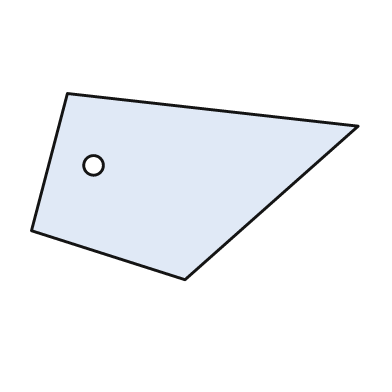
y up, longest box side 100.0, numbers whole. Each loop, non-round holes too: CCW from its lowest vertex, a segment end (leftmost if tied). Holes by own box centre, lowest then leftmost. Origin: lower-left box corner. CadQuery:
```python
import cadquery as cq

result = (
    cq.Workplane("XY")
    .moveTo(47.0, 0.0)
    .lineTo(100.0, 47.0)
    .lineTo(11.0, 57.0)
    .lineTo(0.0, 15.0)
    .close()
    .moveTo(19.0, 35.0)
    .circle(3.0)
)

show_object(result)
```